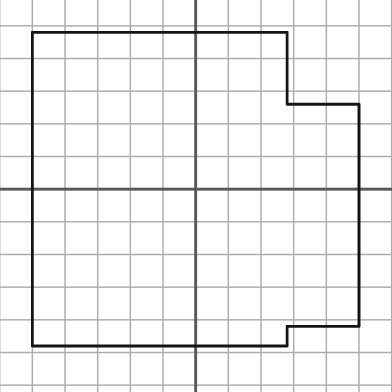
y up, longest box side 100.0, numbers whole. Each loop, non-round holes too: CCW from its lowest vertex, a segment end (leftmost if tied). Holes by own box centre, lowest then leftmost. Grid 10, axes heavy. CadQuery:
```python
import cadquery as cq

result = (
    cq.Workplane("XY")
    .moveTo(-50.0, -48.0)
    .lineTo(28.0, -48.0)
    .lineTo(28.0, -42.0)
    .lineTo(50.0, -42.0)
    .lineTo(50.0, 26.0)
    .lineTo(28.0, 26.0)
    .lineTo(28.0, 48.0)
    .lineTo(-50.0, 48.0)
    .close()
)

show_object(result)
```